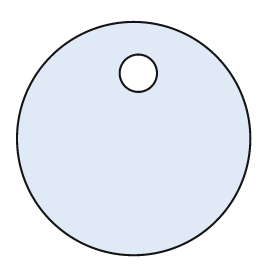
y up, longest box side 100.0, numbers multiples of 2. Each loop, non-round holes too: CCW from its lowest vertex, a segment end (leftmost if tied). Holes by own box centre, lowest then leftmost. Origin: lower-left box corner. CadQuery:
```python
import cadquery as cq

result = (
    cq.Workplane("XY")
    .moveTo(50.0, 50.0)
    .circle(50.0)
    .moveTo(52.0, 78.0)
    .circle(8.0)
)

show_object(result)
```